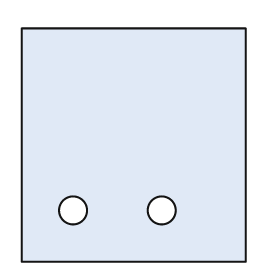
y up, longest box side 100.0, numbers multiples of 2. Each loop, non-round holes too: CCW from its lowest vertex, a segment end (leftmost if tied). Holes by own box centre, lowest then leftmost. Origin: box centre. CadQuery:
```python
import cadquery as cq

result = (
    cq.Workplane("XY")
    .moveTo(-48.0, -50.0)
    .lineTo(48.0, -50.0)
    .lineTo(48.0, 50.0)
    .lineTo(-48.0, 50.0)
    .close()
    .moveTo(-26.0, -28.0)
    .circle(6.0)
    .moveTo(12.0, -28.0)
    .circle(6.0)
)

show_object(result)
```